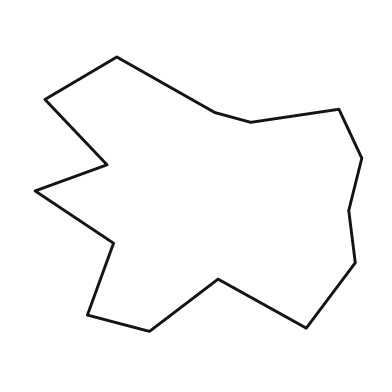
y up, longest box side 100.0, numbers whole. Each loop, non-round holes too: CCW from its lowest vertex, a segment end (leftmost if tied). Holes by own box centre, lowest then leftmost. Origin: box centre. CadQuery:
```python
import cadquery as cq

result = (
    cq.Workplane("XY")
    .moveTo(-15.0, -42.0)
    .lineTo(6.0, -26.0)
    .lineTo(33.0, -41.0)
    .lineTo(48.0, -21.0)
    .lineTo(46.0, -5.0)
    .lineTo(50.0, 11.0)
    .lineTo(43.0, 26.0)
    .lineTo(16.0, 22.0)
    .lineTo(5.0, 25.0)
    .lineTo(-25.0, 42.0)
    .lineTo(-47.0, 29.0)
    .lineTo(-28.0, 9.0)
    .lineTo(-50.0, 1.0)
    .lineTo(-26.0, -15.0)
    .lineTo(-34.0, -37.0)
    .close()
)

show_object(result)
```